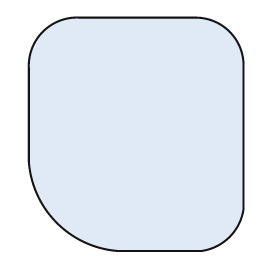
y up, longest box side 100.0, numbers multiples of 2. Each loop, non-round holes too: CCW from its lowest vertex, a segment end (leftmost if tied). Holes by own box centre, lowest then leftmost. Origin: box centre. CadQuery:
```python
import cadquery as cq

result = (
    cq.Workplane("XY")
    .moveTo(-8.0, -50.0)
    .lineTo(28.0, -50.0)
    .threePointArc((40.0, -44.0), (46.0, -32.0))
    .lineTo(46.0, 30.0)
    .threePointArc((40.0, 44.0), (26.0, 50.0))
    .lineTo(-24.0, 50.0)
    .threePointArc((-40.0, 44.0), (-46.0, 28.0))
    .lineTo(-46.0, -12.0)
    .threePointArc((-34.0, -38.0), (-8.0, -50.0))
    .close()
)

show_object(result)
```